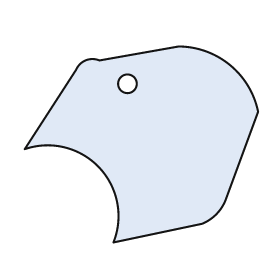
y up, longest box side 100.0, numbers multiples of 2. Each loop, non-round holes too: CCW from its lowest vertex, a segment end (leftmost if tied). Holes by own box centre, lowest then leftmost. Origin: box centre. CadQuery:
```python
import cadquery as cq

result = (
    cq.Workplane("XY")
    .moveTo(-12.0, -42.0)
    .lineTo(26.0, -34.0)
    .threePointArc((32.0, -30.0), (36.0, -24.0))
    .lineTo(50.0, 14.0)
    .threePointArc((38.0, 34.0), (16.0, 42.0))
    .lineTo(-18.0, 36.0)
    .threePointArc((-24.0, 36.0), (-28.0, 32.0))
    .lineTo(-50.0, -2.0)
    .threePointArc((-18.0, -10.0), (-12.0, -42.0))
    .close()
    .moveTo(-6.0, 26.0)
    .circle(4.0)
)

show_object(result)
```